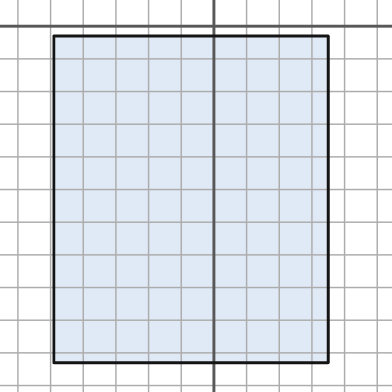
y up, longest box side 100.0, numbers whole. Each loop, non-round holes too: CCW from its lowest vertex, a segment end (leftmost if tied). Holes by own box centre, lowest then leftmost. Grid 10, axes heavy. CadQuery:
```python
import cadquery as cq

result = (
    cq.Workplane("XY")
    .moveTo(-49.0, -103.0)
    .lineTo(35.0, -103.0)
    .lineTo(35.0, -3.0)
    .lineTo(-49.0, -3.0)
    .close()
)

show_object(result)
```